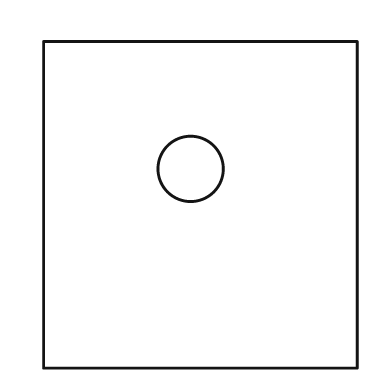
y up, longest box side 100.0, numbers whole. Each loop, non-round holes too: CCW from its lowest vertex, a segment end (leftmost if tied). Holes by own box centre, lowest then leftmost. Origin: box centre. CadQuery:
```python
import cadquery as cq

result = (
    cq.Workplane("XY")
    .moveTo(-48.0, -50.0)
    .lineTo(48.0, -50.0)
    .lineTo(48.0, 50.0)
    .lineTo(-48.0, 50.0)
    .close()
    .moveTo(-3.0, 11.0)
    .circle(10.0)
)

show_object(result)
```